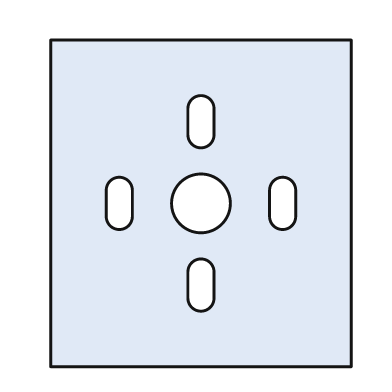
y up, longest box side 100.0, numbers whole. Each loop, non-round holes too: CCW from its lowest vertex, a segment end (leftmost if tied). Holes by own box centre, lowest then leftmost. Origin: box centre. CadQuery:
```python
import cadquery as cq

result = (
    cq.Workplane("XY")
    .moveTo(-46.0, -50.0)
    .lineTo(46.0, -50.0)
    .lineTo(46.0, 50.0)
    .lineTo(-46.0, 50.0)
    .close()
    .moveTo(-4.0, -29.0)
    .threePointArc((0.0, -33.0), (4.0, -29.0))
    .lineTo(4.0, -21.0)
    .threePointArc((0.0, -17.0), (-4.0, -21.0))
    .close()
    .moveTo(-29.0, -4.0)
    .threePointArc((-25.0, -8.0), (-21.0, -4.0))
    .lineTo(-21.0, 4.0)
    .threePointArc((-25.0, 8.0), (-29.0, 4.0))
    .close()
    .moveTo(0.0, 0.0)
    .circle(9.0)
    .moveTo(21.0, -4.0)
    .threePointArc((25.0, -8.0), (29.0, -4.0))
    .lineTo(29.0, 4.0)
    .threePointArc((25.0, 8.0), (21.0, 4.0))
    .close()
    .moveTo(-4.0, 21.0)
    .threePointArc((0.0, 17.0), (4.0, 21.0))
    .lineTo(4.0, 29.0)
    .threePointArc((0.0, 33.0), (-4.0, 29.0))
    .close()
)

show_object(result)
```